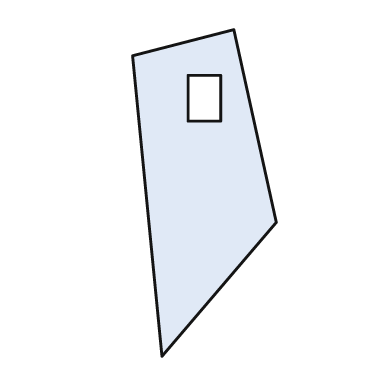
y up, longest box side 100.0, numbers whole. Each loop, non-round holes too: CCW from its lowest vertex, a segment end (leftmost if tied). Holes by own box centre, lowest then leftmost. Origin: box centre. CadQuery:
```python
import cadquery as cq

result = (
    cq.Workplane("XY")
    .moveTo(-13.0, -50.0)
    .lineTo(22.0, -9.0)
    .lineTo(9.0, 50.0)
    .lineTo(-22.0, 42.0)
    .close()
    .moveTo(-5.0, 22.0)
    .lineTo(5.0, 22.0)
    .lineTo(5.0, 36.0)
    .lineTo(-5.0, 36.0)
    .close()
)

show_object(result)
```